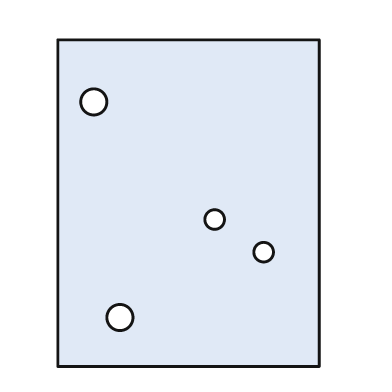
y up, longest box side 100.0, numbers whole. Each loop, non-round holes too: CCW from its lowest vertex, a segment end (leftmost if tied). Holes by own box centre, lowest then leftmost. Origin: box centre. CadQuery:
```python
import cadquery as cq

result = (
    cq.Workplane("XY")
    .moveTo(-40.0, -50.0)
    .lineTo(40.0, -50.0)
    .lineTo(40.0, 50.0)
    .lineTo(-40.0, 50.0)
    .close()
    .moveTo(-21.0, -35.0)
    .circle(4.0)
    .moveTo(23.0, -15.0)
    .circle(3.0)
    .moveTo(8.0, -5.0)
    .circle(3.0)
    .moveTo(-29.0, 31.0)
    .circle(4.0)
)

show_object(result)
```